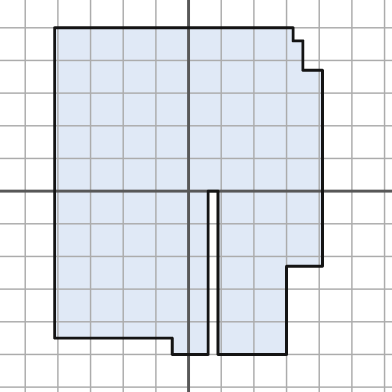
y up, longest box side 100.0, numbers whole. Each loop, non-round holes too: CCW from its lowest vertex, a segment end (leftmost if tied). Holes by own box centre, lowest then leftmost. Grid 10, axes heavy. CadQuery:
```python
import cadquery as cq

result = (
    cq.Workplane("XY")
    .moveTo(-5.0, -50.0)
    .lineTo(6.0, -50.0)
    .lineTo(6.0, 0.0)
    .lineTo(9.0, 0.0)
    .lineTo(9.0, -50.0)
    .lineTo(30.0, -50.0)
    .lineTo(30.0, -23.0)
    .lineTo(41.0, -23.0)
    .lineTo(41.0, 37.0)
    .lineTo(35.0, 37.0)
    .lineTo(35.0, 46.0)
    .lineTo(32.0, 46.0)
    .lineTo(32.0, 50.0)
    .lineTo(-41.0, 50.0)
    .lineTo(-41.0, -45.0)
    .lineTo(-5.0, -45.0)
    .close()
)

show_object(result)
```